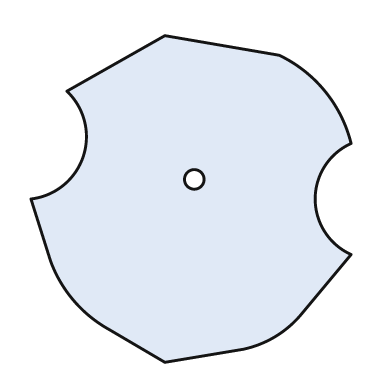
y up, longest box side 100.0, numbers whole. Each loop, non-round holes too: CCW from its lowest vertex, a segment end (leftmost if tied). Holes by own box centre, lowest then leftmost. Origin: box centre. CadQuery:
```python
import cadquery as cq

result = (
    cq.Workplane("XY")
    .moveTo(-8.0, -50.0)
    .lineTo(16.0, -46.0)
    .threePointArc((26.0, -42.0), (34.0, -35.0))
    .lineTo(49.0, -17.0)
    .threePointArc((38.0, 0.0), (49.0, 17.0))
    .threePointArc((41.0, 33.0), (27.0, 44.0))
    .lineTo(-8.0, 50.0)
    .lineTo(-38.0, 33.0)
    .threePointArc((-33.0, 13.0), (-49.0, 0.0))
    .lineTo(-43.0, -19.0)
    .threePointArc((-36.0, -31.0), (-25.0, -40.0))
    .close()
    .moveTo(1.0, 6.0)
    .circle(3.0)
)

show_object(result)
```